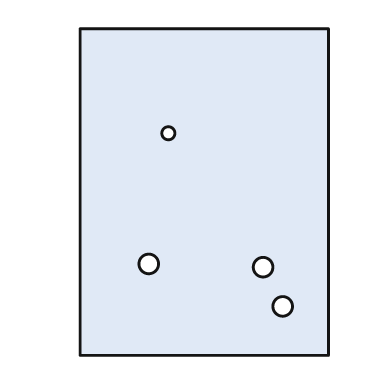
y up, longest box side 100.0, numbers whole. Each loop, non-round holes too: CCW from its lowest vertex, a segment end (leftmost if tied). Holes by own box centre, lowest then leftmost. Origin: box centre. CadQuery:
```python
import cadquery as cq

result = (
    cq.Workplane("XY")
    .moveTo(-38.0, -50.0)
    .lineTo(38.0, -50.0)
    .lineTo(38.0, 50.0)
    .lineTo(-38.0, 50.0)
    .close()
    .moveTo(24.0, -35.0)
    .circle(3.0)
    .moveTo(18.0, -23.0)
    .circle(3.0)
    .moveTo(-17.0, -22.0)
    .circle(3.0)
    .moveTo(-11.0, 18.0)
    .circle(2.0)
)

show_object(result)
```